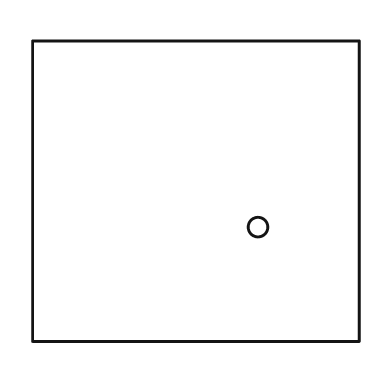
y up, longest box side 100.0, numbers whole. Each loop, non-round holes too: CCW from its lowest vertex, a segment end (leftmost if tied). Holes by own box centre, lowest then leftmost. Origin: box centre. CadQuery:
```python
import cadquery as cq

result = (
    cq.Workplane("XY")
    .moveTo(-50.0, -46.0)
    .lineTo(50.0, -46.0)
    .lineTo(50.0, 46.0)
    .lineTo(-50.0, 46.0)
    .close()
    .moveTo(19.0, -11.0)
    .circle(3.0)
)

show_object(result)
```